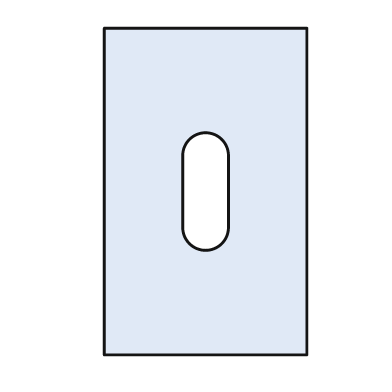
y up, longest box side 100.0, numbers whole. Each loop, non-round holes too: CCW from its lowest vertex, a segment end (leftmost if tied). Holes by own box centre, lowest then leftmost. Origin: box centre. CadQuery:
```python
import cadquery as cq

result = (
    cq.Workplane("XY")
    .moveTo(-31.0, -50.0)
    .lineTo(31.0, -50.0)
    .lineTo(31.0, 50.0)
    .lineTo(-31.0, 50.0)
    .close()
    .moveTo(-7.0, -11.0)
    .threePointArc((0.0, -18.0), (7.0, -11.0))
    .lineTo(7.0, 11.0)
    .threePointArc((0.0, 18.0), (-7.0, 11.0))
    .close()
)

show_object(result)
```